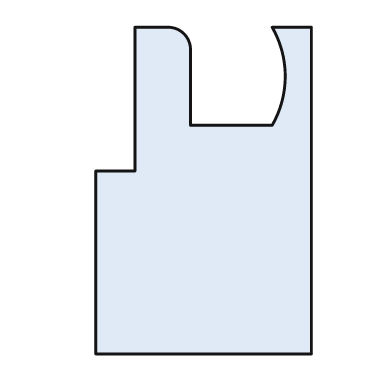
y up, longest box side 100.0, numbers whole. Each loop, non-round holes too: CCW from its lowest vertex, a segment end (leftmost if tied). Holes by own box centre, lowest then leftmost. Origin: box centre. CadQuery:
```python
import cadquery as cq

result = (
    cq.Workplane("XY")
    .moveTo(-33.0, -50.0)
    .lineTo(33.0, -50.0)
    .lineTo(33.0, 50.0)
    .lineTo(21.0, 50.0)
    .threePointArc((25.0, 35.0), (21.0, 20.0))
    .lineTo(-4.0, 20.0)
    .lineTo(-4.0, 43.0)
    .threePointArc((-6.0, 48.0), (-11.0, 50.0))
    .lineTo(-21.0, 50.0)
    .lineTo(-21.0, 6.0)
    .lineTo(-33.0, 6.0)
    .close()
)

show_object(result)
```